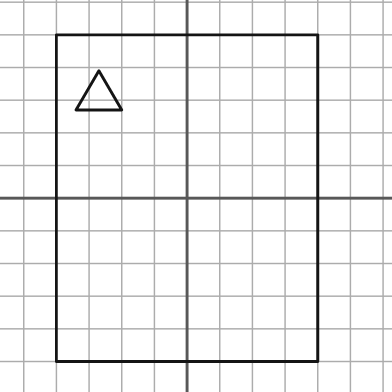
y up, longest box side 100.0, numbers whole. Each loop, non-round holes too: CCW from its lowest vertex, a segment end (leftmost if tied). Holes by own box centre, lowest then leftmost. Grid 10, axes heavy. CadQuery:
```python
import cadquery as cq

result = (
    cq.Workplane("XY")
    .moveTo(-40.0, -50.0)
    .lineTo(40.0, -50.0)
    .lineTo(40.0, 50.0)
    .lineTo(-40.0, 50.0)
    .close()
    .moveTo(-34.0, 27.0)
    .lineTo(-20.0, 27.0)
    .lineTo(-27.0, 39.0)
    .close()
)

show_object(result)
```